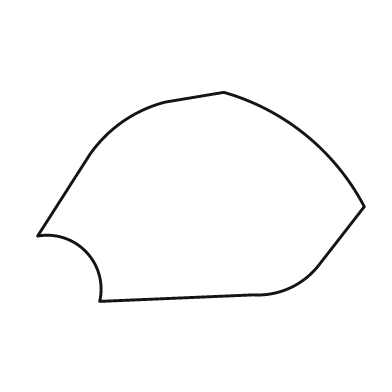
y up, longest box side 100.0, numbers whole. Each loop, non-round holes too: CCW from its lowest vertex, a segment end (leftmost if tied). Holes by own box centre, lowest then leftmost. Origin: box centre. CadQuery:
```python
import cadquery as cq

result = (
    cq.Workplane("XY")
    .moveTo(-31.0, -32.0)
    .lineTo(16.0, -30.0)
    .threePointArc((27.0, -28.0), (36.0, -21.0))
    .lineTo(50.0, -3.0)
    .threePointArc((32.0, 19.0), (7.0, 32.0))
    .lineTo(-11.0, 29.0)
    .threePointArc((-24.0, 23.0), (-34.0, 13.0))
    .lineTo(-50.0, -12.0)
    .threePointArc((-35.0, -17.0), (-31.0, -32.0))
    .close()
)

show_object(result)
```